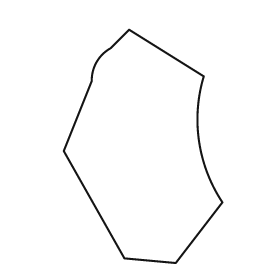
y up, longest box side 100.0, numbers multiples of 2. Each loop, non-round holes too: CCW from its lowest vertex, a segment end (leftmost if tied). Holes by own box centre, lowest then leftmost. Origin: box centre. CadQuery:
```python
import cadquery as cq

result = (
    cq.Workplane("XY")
    .moveTo(14.0, -50.0)
    .lineTo(34.0, -24.0)
    .threePointArc((24.0, 2.0), (26.0, 30.0))
    .lineTo(-6.0, 50.0)
    .lineTo(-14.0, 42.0)
    .threePointArc((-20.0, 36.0), (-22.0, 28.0))
    .lineTo(-34.0, -2.0)
    .lineTo(-8.0, -48.0)
    .close()
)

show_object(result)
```